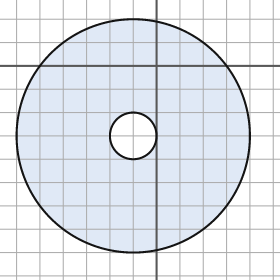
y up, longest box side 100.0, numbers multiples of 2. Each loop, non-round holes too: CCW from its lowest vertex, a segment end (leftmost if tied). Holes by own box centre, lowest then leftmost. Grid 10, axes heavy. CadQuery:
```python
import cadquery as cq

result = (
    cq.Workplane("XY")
    .moveTo(-10.0, -30.0)
    .circle(50.0)
    .moveTo(-10.0, -30.0)
    .circle(10.0)
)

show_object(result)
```